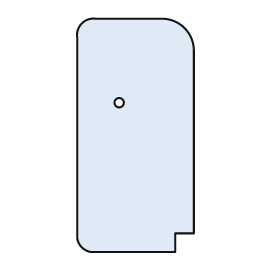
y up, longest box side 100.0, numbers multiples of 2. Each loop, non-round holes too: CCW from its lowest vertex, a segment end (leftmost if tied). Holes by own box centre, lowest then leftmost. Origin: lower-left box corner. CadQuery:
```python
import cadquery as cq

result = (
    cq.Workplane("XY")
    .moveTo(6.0, 0.0)
    .lineTo(42.0, 0.0)
    .lineTo(42.0, 8.0)
    .lineTo(50.0, 8.0)
    .lineTo(50.0, 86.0)
    .threePointArc((46.0, 96.0), (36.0, 100.0))
    .lineTo(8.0, 100.0)
    .threePointArc((2.0, 98.0), (0.0, 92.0))
    .lineTo(0.0, 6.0)
    .threePointArc((2.0, 2.0), (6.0, 0.0))
    .close()
    .moveTo(18.0, 64.0)
    .circle(2.0)
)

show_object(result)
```